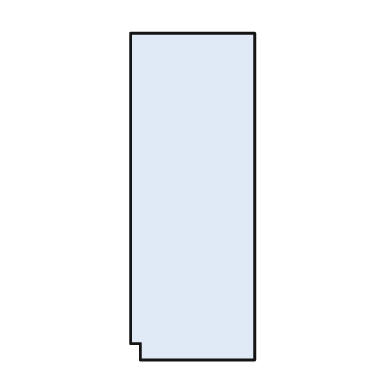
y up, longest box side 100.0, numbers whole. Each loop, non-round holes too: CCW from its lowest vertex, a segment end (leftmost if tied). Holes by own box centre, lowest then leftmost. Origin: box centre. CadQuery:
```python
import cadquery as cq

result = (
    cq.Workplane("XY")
    .moveTo(-16.0, -50.0)
    .lineTo(19.0, -50.0)
    .lineTo(19.0, 50.0)
    .lineTo(-19.0, 50.0)
    .lineTo(-19.0, -45.0)
    .lineTo(-16.0, -45.0)
    .close()
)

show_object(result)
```